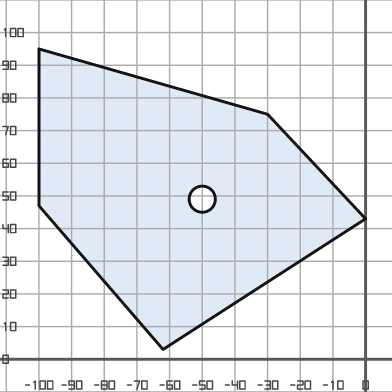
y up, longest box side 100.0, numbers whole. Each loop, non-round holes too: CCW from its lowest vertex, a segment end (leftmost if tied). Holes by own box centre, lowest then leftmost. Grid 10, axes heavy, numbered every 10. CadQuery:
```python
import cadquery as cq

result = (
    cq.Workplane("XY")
    .moveTo(-62.0, 3.0)
    .lineTo(0.0, 43.0)
    .lineTo(-30.0, 75.0)
    .lineTo(-100.0, 95.0)
    .lineTo(-100.0, 47.0)
    .close()
    .moveTo(-50.0, 49.0)
    .circle(4.0)
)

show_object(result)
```